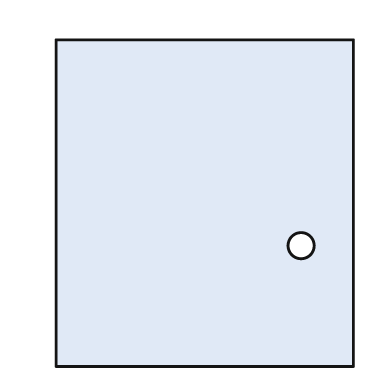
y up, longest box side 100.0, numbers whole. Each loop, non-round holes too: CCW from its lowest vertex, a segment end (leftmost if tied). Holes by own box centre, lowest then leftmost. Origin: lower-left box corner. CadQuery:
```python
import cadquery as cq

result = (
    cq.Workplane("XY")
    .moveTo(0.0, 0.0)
    .lineTo(91.0, 0.0)
    .lineTo(91.0, 100.0)
    .lineTo(0.0, 100.0)
    .close()
    .moveTo(75.0, 37.0)
    .circle(4.0)
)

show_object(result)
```